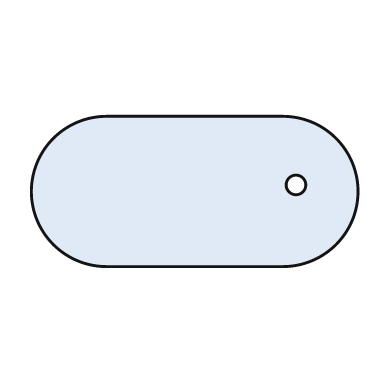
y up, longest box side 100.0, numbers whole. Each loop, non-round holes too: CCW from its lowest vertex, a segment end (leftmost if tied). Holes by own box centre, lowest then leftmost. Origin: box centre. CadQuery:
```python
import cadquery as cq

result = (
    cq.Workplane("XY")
    .moveTo(-27.0, -23.0)
    .lineTo(27.0, -23.0)
    .threePointArc((50.0, 0.0), (27.0, 23.0))
    .lineTo(-27.0, 23.0)
    .threePointArc((-50.0, 0.0), (-27.0, -23.0))
    .close()
    .moveTo(31.0, 2.0)
    .circle(3.0)
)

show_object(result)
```